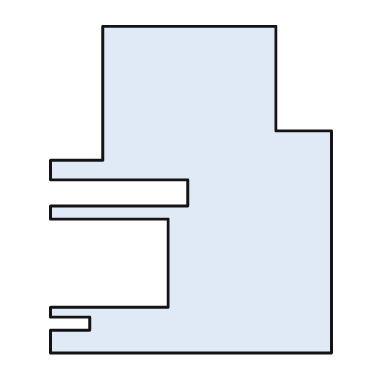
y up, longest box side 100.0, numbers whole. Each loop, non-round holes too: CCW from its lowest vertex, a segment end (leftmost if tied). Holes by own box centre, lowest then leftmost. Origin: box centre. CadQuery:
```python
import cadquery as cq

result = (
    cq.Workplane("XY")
    .moveTo(-43.0, -50.0)
    .lineTo(43.0, -50.0)
    .lineTo(43.0, 18.0)
    .lineTo(26.0, 18.0)
    .lineTo(26.0, 50.0)
    .lineTo(-27.0, 50.0)
    .lineTo(-27.0, 9.0)
    .lineTo(-43.0, 9.0)
    .lineTo(-43.0, 3.0)
    .lineTo(-1.0, 3.0)
    .lineTo(-1.0, -5.0)
    .lineTo(-43.0, -5.0)
    .lineTo(-43.0, -9.0)
    .lineTo(-7.0, -9.0)
    .lineTo(-7.0, -36.0)
    .lineTo(-43.0, -36.0)
    .lineTo(-43.0, -39.0)
    .lineTo(-31.0, -39.0)
    .lineTo(-31.0, -43.0)
    .lineTo(-43.0, -43.0)
    .close()
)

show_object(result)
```